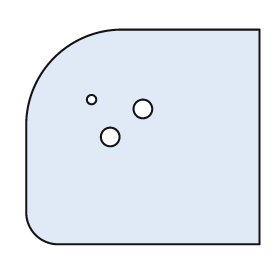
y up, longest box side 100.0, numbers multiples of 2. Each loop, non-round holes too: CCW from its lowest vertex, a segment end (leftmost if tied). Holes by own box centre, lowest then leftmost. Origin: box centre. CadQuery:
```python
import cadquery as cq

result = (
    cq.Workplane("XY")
    .moveTo(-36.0, -46.0)
    .lineTo(50.0, -46.0)
    .lineTo(50.0, 46.0)
    .lineTo(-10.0, 46.0)
    .threePointArc((-38.0, 34.0), (-50.0, 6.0))
    .lineTo(-50.0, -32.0)
    .threePointArc((-46.0, -42.0), (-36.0, -46.0))
    .close()
    .moveTo(-14.0, 0.0)
    .circle(4.0)
    .moveTo(0.0, 12.0)
    .circle(4.0)
    .moveTo(-22.0, 16.0)
    .circle(2.0)
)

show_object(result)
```